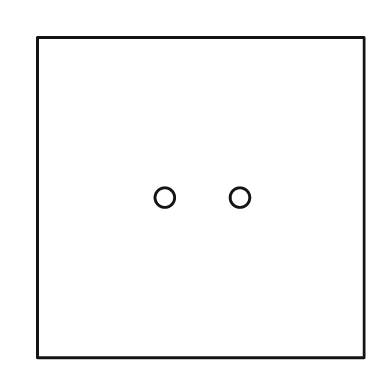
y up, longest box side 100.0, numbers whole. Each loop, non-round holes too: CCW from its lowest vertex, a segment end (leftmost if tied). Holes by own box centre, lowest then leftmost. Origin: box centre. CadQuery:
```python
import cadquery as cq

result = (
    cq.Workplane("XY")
    .moveTo(-50.0, -49.0)
    .lineTo(50.0, -49.0)
    .lineTo(50.0, 49.0)
    .lineTo(-50.0, 49.0)
    .close()
    .moveTo(-11.0, 0.0)
    .circle(3.0)
    .moveTo(12.0, 0.0)
    .circle(3.0)
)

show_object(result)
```